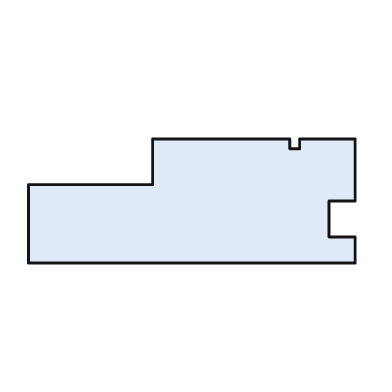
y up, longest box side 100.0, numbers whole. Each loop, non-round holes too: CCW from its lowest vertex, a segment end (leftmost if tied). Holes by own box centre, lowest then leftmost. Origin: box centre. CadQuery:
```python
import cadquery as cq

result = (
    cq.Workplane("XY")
    .moveTo(-50.0, -19.0)
    .lineTo(50.0, -19.0)
    .lineTo(50.0, -11.0)
    .lineTo(42.0, -11.0)
    .lineTo(42.0, 0.0)
    .lineTo(50.0, 0.0)
    .lineTo(50.0, 19.0)
    .lineTo(33.0, 19.0)
    .lineTo(33.0, 16.0)
    .lineTo(30.0, 16.0)
    .lineTo(30.0, 19.0)
    .lineTo(-12.0, 19.0)
    .lineTo(-12.0, 5.0)
    .lineTo(-50.0, 5.0)
    .close()
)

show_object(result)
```